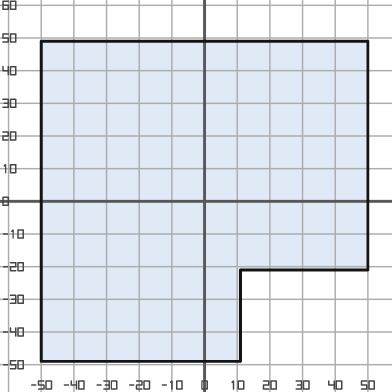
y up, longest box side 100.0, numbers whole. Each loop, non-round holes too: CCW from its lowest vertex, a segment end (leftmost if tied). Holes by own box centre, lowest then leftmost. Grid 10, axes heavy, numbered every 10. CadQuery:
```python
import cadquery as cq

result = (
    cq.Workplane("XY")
    .moveTo(-50.0, -49.0)
    .lineTo(11.0, -49.0)
    .lineTo(11.0, -21.0)
    .lineTo(50.0, -21.0)
    .lineTo(50.0, 49.0)
    .lineTo(-50.0, 49.0)
    .close()
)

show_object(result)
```